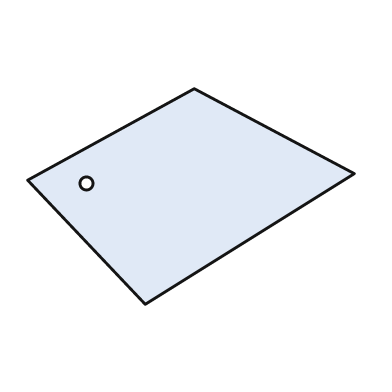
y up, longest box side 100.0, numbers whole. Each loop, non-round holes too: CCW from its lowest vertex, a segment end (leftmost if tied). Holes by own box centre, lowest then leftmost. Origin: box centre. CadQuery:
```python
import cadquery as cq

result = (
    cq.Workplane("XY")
    .moveTo(-14.0, -33.0)
    .lineTo(50.0, 7.0)
    .lineTo(1.0, 33.0)
    .lineTo(-50.0, 5.0)
    .close()
    .moveTo(-32.0, 4.0)
    .circle(2.0)
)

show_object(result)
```